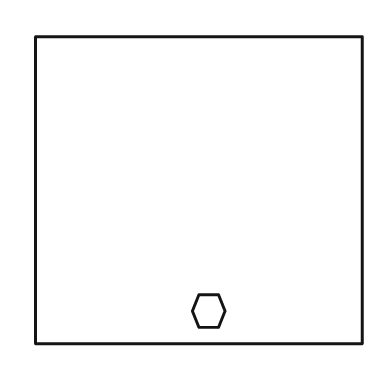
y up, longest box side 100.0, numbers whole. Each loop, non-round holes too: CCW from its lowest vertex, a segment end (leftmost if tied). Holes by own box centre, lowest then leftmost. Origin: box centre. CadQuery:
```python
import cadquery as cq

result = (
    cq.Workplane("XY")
    .moveTo(-50.0, -47.0)
    .lineTo(50.0, -47.0)
    .lineTo(50.0, 47.0)
    .lineTo(-50.0, 47.0)
    .close()
    .moveTo(0.0, -42.0)
    .lineTo(6.0, -42.0)
    .lineTo(8.0, -37.0)
    .lineTo(6.0, -32.0)
    .lineTo(0.0, -32.0)
    .lineTo(-2.0, -37.0)
    .close()
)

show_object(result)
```